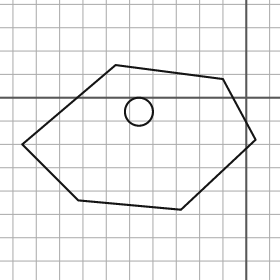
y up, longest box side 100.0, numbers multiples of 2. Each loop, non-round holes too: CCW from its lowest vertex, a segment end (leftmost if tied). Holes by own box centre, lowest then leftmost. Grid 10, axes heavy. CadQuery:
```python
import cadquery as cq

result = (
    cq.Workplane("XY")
    .moveTo(-28.0, -48.0)
    .lineTo(4.0, -18.0)
    .lineTo(-10.0, 8.0)
    .lineTo(-56.0, 14.0)
    .lineTo(-96.0, -20.0)
    .lineTo(-72.0, -44.0)
    .close()
    .moveTo(-46.0, -6.0)
    .circle(6.0)
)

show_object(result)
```